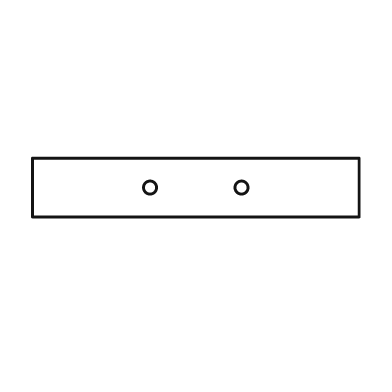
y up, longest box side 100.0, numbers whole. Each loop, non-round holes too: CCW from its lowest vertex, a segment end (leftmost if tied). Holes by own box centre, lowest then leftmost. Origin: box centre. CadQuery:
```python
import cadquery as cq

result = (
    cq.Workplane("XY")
    .moveTo(-50.0, -9.0)
    .lineTo(50.0, -9.0)
    .lineTo(50.0, 9.0)
    .lineTo(-50.0, 9.0)
    .close()
    .moveTo(-14.0, 0.0)
    .circle(2.0)
    .moveTo(14.0, 0.0)
    .circle(2.0)
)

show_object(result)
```